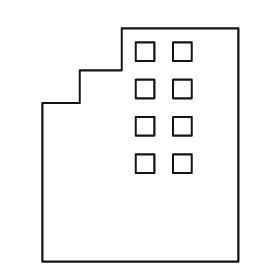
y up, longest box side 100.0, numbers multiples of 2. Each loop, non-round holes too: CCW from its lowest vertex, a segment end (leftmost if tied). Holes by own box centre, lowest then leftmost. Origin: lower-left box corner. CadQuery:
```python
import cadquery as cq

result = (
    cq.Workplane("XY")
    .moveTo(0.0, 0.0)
    .lineTo(84.0, 0.0)
    .lineTo(84.0, 100.0)
    .lineTo(34.0, 100.0)
    .lineTo(34.0, 82.0)
    .lineTo(16.0, 82.0)
    .lineTo(16.0, 68.0)
    .lineTo(0.0, 68.0)
    .close()
    .moveTo(40.0, 38.0)
    .lineTo(48.0, 38.0)
    .lineTo(48.0, 46.0)
    .lineTo(40.0, 46.0)
    .close()
    .moveTo(56.0, 38.0)
    .lineTo(64.0, 38.0)
    .lineTo(64.0, 46.0)
    .lineTo(56.0, 46.0)
    .close()
    .moveTo(40.0, 54.0)
    .lineTo(48.0, 54.0)
    .lineTo(48.0, 62.0)
    .lineTo(40.0, 62.0)
    .close()
    .moveTo(56.0, 54.0)
    .lineTo(64.0, 54.0)
    .lineTo(64.0, 62.0)
    .lineTo(56.0, 62.0)
    .close()
    .moveTo(40.0, 70.0)
    .lineTo(48.0, 70.0)
    .lineTo(48.0, 78.0)
    .lineTo(40.0, 78.0)
    .close()
    .moveTo(56.0, 70.0)
    .lineTo(64.0, 70.0)
    .lineTo(64.0, 78.0)
    .lineTo(56.0, 78.0)
    .close()
    .moveTo(40.0, 86.0)
    .lineTo(48.0, 86.0)
    .lineTo(48.0, 94.0)
    .lineTo(40.0, 94.0)
    .close()
    .moveTo(56.0, 86.0)
    .lineTo(64.0, 86.0)
    .lineTo(64.0, 94.0)
    .lineTo(56.0, 94.0)
    .close()
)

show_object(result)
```